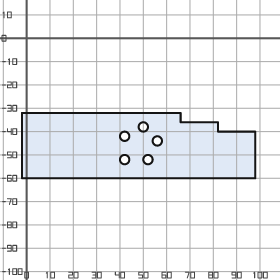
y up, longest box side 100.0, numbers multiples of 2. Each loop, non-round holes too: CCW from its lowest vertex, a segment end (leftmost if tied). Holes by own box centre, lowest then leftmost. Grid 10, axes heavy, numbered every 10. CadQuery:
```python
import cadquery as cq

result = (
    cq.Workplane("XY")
    .moveTo(-2.0, -60.0)
    .lineTo(98.0, -60.0)
    .lineTo(98.0, -40.0)
    .lineTo(82.0, -40.0)
    .lineTo(82.0, -36.0)
    .lineTo(66.0, -36.0)
    .lineTo(66.0, -32.0)
    .lineTo(-2.0, -32.0)
    .close()
    .moveTo(42.0, -52.0)
    .circle(2.0)
    .moveTo(52.0, -52.0)
    .circle(2.0)
    .moveTo(56.0, -44.0)
    .circle(2.0)
    .moveTo(42.0, -42.0)
    .circle(2.0)
    .moveTo(50.0, -38.0)
    .circle(2.0)
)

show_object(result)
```